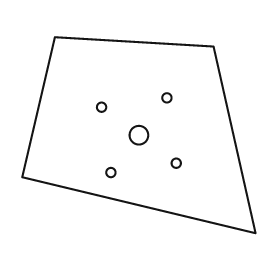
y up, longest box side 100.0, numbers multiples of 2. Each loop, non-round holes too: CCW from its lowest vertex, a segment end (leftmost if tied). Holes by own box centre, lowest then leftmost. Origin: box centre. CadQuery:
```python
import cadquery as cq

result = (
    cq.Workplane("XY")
    .moveTo(50.0, -42.0)
    .lineTo(32.0, 38.0)
    .lineTo(-36.0, 42.0)
    .lineTo(-50.0, -18.0)
    .close()
    .moveTo(-12.0, -16.0)
    .circle(2.0)
    .moveTo(16.0, -12.0)
    .circle(2.0)
    .moveTo(0.0, 0.0)
    .circle(4.0)
    .moveTo(-16.0, 12.0)
    .circle(2.0)
    .moveTo(12.0, 16.0)
    .circle(2.0)
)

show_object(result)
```